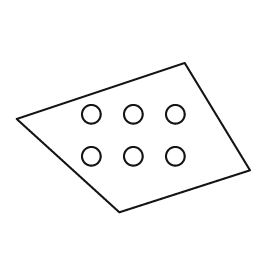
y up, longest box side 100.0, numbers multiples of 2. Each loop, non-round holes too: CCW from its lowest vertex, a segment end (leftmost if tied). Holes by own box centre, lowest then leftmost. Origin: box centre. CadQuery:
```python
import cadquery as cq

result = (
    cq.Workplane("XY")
    .moveTo(-6.0, -32.0)
    .lineTo(50.0, -14.0)
    .lineTo(22.0, 32.0)
    .lineTo(-50.0, 8.0)
    .close()
    .moveTo(-18.0, -8.0)
    .circle(4.0)
    .moveTo(0.0, -8.0)
    .circle(4.0)
    .moveTo(18.0, -8.0)
    .circle(4.0)
    .moveTo(-18.0, 10.0)
    .circle(4.0)
    .moveTo(0.0, 10.0)
    .circle(4.0)
    .moveTo(18.0, 10.0)
    .circle(4.0)
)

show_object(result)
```